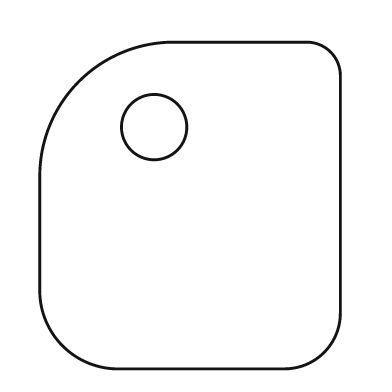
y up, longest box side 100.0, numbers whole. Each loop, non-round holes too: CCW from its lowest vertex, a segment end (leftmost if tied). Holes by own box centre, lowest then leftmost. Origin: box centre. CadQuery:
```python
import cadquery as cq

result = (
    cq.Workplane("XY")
    .moveTo(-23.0, -50.0)
    .lineTo(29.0, -50.0)
    .threePointArc((41.0, -45.0), (46.0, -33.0))
    .lineTo(46.0, 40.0)
    .threePointArc((43.0, 47.0), (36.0, 50.0))
    .lineTo(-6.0, 50.0)
    .threePointArc((-34.0, 38.0), (-46.0, 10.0))
    .lineTo(-46.0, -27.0)
    .threePointArc((-39.0, -43.0), (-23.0, -50.0))
    .close()
    .moveTo(-11.0, 24.0)
    .circle(10.0)
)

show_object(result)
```